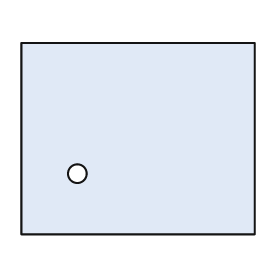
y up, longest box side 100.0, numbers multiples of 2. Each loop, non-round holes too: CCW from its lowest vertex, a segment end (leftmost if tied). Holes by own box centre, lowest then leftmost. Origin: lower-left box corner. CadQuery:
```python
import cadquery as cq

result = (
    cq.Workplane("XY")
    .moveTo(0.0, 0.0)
    .lineTo(100.0, 0.0)
    .lineTo(100.0, 82.0)
    .lineTo(0.0, 82.0)
    .close()
    .moveTo(24.0, 26.0)
    .circle(4.0)
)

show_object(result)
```